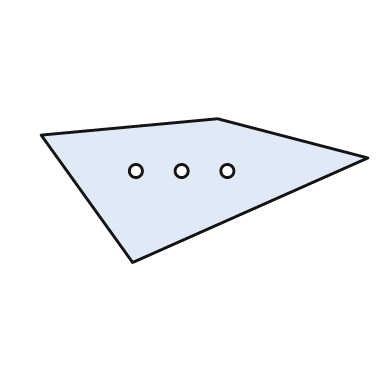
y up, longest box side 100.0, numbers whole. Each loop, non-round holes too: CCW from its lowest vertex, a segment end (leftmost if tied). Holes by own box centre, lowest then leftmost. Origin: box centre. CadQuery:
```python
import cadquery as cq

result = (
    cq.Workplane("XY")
    .moveTo(-22.0, -22.0)
    .lineTo(50.0, 10.0)
    .lineTo(4.0, 22.0)
    .lineTo(-50.0, 17.0)
    .close()
    .moveTo(-21.0, 6.0)
    .circle(2.0)
    .moveTo(-7.0, 6.0)
    .circle(2.0)
    .moveTo(7.0, 6.0)
    .circle(2.0)
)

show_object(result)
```